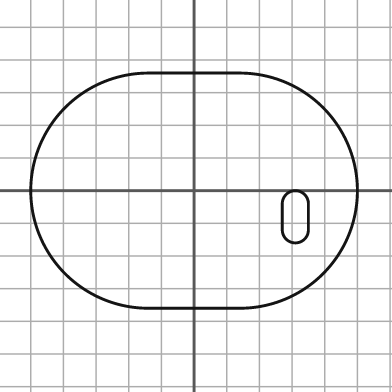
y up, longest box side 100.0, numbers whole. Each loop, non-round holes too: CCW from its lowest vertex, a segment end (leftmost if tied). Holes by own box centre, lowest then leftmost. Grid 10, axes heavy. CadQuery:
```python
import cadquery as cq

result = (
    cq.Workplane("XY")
    .moveTo(-14.0, -36.0)
    .lineTo(14.0, -36.0)
    .threePointArc((50.0, 0.0), (14.0, 36.0))
    .lineTo(-14.0, 36.0)
    .threePointArc((-50.0, 0.0), (-14.0, -36.0))
    .close()
    .moveTo(27.0, -12.0)
    .threePointArc((31.0, -16.0), (35.0, -12.0))
    .lineTo(35.0, -4.0)
    .threePointArc((31.0, 0.0), (27.0, -4.0))
    .close()
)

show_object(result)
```